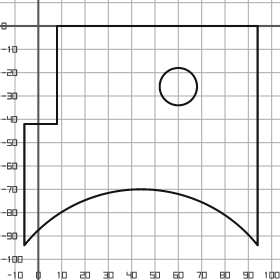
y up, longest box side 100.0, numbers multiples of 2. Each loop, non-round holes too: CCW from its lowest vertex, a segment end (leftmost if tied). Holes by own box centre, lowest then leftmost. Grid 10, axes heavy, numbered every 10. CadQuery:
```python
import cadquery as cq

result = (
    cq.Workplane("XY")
    .moveTo(-6.0, -94.0)
    .threePointArc((44.0, -70.0), (94.0, -94.0))
    .lineTo(94.0, 0.0)
    .lineTo(8.0, 0.0)
    .lineTo(8.0, -42.0)
    .lineTo(-6.0, -42.0)
    .close()
    .moveTo(60.0, -26.0)
    .circle(8.0)
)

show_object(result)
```